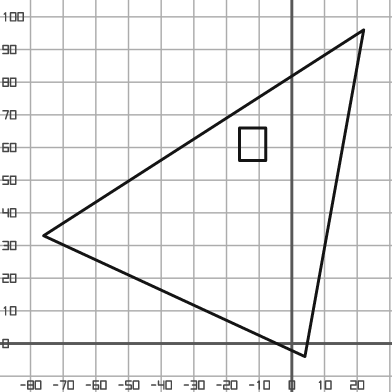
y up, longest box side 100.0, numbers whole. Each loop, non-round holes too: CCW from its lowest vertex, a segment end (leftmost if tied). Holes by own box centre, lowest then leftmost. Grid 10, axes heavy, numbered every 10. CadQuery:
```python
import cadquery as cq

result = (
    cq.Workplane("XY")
    .moveTo(4.0, -4.0)
    .lineTo(22.0, 96.0)
    .lineTo(-76.0, 33.0)
    .close()
    .moveTo(-16.0, 56.0)
    .lineTo(-8.0, 56.0)
    .lineTo(-8.0, 66.0)
    .lineTo(-16.0, 66.0)
    .close()
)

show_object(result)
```